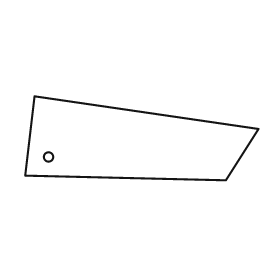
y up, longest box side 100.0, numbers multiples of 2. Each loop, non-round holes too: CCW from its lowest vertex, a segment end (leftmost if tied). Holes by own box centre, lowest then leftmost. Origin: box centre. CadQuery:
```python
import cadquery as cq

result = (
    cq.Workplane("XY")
    .moveTo(36.0, -18.0)
    .lineTo(50.0, 4.0)
    .lineTo(-46.0, 18.0)
    .lineTo(-50.0, -16.0)
    .close()
    .moveTo(-40.0, -8.0)
    .circle(2.0)
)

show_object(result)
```